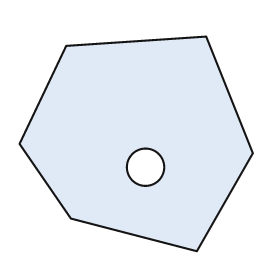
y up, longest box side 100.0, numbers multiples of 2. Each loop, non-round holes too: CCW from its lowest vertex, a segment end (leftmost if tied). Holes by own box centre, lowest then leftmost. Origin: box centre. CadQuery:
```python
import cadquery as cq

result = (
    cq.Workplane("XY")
    .moveTo(26.0, -46.0)
    .lineTo(50.0, -4.0)
    .lineTo(30.0, 46.0)
    .lineTo(-30.0, 42.0)
    .lineTo(-50.0, 0.0)
    .lineTo(-28.0, -32.0)
    .close()
    .moveTo(4.0, -10.0)
    .circle(8.0)
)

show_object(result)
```